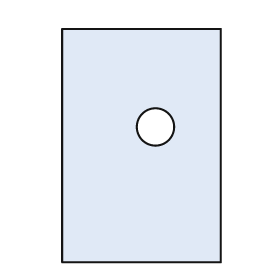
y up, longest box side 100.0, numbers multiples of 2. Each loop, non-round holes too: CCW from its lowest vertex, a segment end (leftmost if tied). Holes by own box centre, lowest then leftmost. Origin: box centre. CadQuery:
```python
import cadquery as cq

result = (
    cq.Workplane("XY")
    .moveTo(-34.0, -50.0)
    .lineTo(34.0, -50.0)
    .lineTo(34.0, 50.0)
    .lineTo(-34.0, 50.0)
    .close()
    .moveTo(6.0, 8.0)
    .circle(8.0)
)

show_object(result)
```